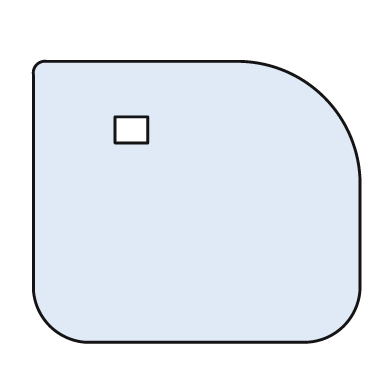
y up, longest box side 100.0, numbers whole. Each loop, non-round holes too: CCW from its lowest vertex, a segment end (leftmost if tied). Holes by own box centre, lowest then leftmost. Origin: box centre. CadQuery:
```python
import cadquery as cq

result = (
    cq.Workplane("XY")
    .moveTo(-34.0, -43.0)
    .lineTo(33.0, -43.0)
    .threePointArc((45.0, -38.0), (50.0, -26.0))
    .lineTo(50.0, 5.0)
    .threePointArc((39.0, 32.0), (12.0, 43.0))
    .lineTo(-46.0, 43.0)
    .threePointArc((-49.0, 42.0), (-50.0, 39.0))
    .lineTo(-50.0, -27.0)
    .threePointArc((-45.0, -38.0), (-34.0, -43.0))
    .close()
    .moveTo(-25.0, 18.0)
    .lineTo(-15.0, 18.0)
    .lineTo(-15.0, 26.0)
    .lineTo(-25.0, 26.0)
    .close()
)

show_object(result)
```